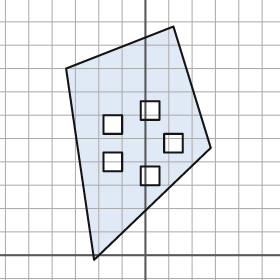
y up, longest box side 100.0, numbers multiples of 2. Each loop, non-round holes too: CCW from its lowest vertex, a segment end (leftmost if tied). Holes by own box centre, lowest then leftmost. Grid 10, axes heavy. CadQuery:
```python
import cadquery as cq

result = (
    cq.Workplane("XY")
    .moveTo(-22.0, -2.0)
    .lineTo(28.0, 46.0)
    .lineTo(12.0, 98.0)
    .lineTo(-34.0, 80.0)
    .close()
    .moveTo(-2.0, 30.0)
    .lineTo(6.0, 30.0)
    .lineTo(6.0, 38.0)
    .lineTo(-2.0, 38.0)
    .close()
    .moveTo(-18.0, 36.0)
    .lineTo(-10.0, 36.0)
    .lineTo(-10.0, 44.0)
    .lineTo(-18.0, 44.0)
    .close()
    .moveTo(8.0, 44.0)
    .lineTo(16.0, 44.0)
    .lineTo(16.0, 52.0)
    .lineTo(8.0, 52.0)
    .close()
    .moveTo(-18.0, 52.0)
    .lineTo(-10.0, 52.0)
    .lineTo(-10.0, 60.0)
    .lineTo(-18.0, 60.0)
    .close()
    .moveTo(-2.0, 58.0)
    .lineTo(6.0, 58.0)
    .lineTo(6.0, 66.0)
    .lineTo(-2.0, 66.0)
    .close()
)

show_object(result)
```